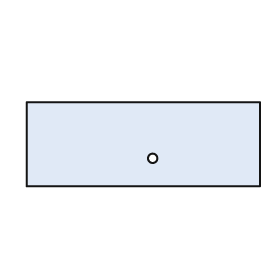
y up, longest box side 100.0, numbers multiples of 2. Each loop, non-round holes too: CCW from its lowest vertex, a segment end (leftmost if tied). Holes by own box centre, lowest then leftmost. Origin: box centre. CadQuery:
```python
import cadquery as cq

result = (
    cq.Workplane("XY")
    .moveTo(-50.0, -18.0)
    .lineTo(50.0, -18.0)
    .lineTo(50.0, 18.0)
    .lineTo(-50.0, 18.0)
    .close()
    .moveTo(4.0, -6.0)
    .circle(2.0)
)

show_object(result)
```